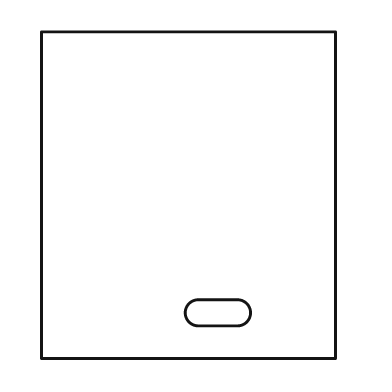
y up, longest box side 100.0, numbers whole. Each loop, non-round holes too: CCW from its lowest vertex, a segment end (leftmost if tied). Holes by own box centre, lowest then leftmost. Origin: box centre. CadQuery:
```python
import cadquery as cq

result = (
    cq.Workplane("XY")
    .moveTo(-45.0, -50.0)
    .lineTo(45.0, -50.0)
    .lineTo(45.0, 50.0)
    .lineTo(-45.0, 50.0)
    .close()
    .moveTo(3.0, -40.0)
    .lineTo(15.0, -40.0)
    .threePointArc((19.0, -36.0), (15.0, -32.0))
    .lineTo(3.0, -32.0)
    .threePointArc((-1.0, -36.0), (3.0, -40.0))
    .close()
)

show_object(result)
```